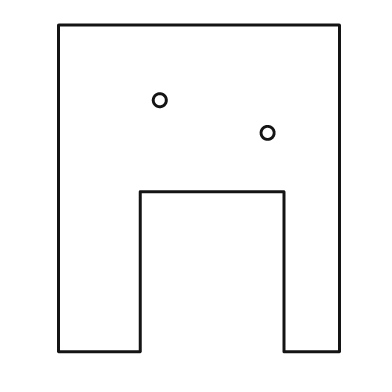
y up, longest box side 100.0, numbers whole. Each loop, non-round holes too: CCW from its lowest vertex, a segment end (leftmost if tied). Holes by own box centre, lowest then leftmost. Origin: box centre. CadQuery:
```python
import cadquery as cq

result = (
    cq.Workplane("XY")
    .moveTo(-43.0, -50.0)
    .lineTo(-18.0, -50.0)
    .lineTo(-18.0, -1.0)
    .lineTo(26.0, -1.0)
    .lineTo(26.0, -50.0)
    .lineTo(43.0, -50.0)
    .lineTo(43.0, 50.0)
    .lineTo(-43.0, 50.0)
    .close()
    .moveTo(21.0, 17.0)
    .circle(2.0)
    .moveTo(-12.0, 27.0)
    .circle(2.0)
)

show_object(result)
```